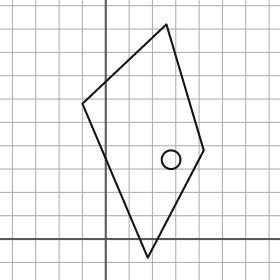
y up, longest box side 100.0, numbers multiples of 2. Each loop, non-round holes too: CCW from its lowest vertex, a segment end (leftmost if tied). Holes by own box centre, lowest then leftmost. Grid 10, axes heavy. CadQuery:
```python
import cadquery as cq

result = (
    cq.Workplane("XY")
    .moveTo(18.0, -8.0)
    .lineTo(42.0, 38.0)
    .lineTo(26.0, 92.0)
    .lineTo(-10.0, 58.0)
    .close()
    .moveTo(28.0, 34.0)
    .circle(4.0)
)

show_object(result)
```